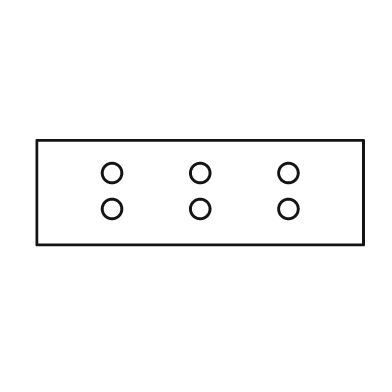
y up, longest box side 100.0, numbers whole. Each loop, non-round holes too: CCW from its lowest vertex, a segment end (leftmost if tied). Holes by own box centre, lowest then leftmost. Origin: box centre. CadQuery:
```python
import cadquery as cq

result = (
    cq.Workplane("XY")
    .moveTo(-50.0, -16.0)
    .lineTo(50.0, -16.0)
    .lineTo(50.0, 16.0)
    .lineTo(-50.0, 16.0)
    .close()
    .moveTo(-27.0, -5.0)
    .circle(3.0)
    .moveTo(0.0, -5.0)
    .circle(3.0)
    .moveTo(27.0, -5.0)
    .circle(3.0)
    .moveTo(-27.0, 6.0)
    .circle(3.0)
    .moveTo(0.0, 6.0)
    .circle(3.0)
    .moveTo(27.0, 6.0)
    .circle(3.0)
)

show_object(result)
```